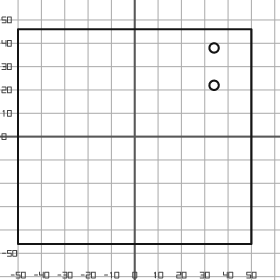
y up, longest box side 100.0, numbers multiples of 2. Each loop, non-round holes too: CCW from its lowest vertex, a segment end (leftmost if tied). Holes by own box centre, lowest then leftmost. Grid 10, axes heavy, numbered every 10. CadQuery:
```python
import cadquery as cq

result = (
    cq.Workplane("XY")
    .moveTo(-50.0, -46.0)
    .lineTo(50.0, -46.0)
    .lineTo(50.0, 46.0)
    .lineTo(-50.0, 46.0)
    .close()
    .moveTo(34.0, 22.0)
    .circle(2.0)
    .moveTo(34.0, 38.0)
    .circle(2.0)
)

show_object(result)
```